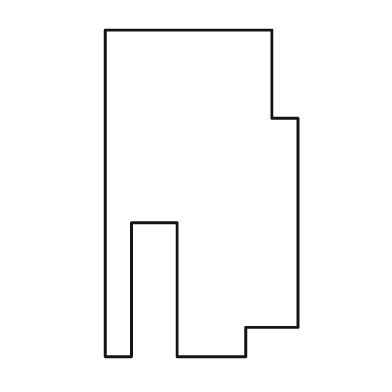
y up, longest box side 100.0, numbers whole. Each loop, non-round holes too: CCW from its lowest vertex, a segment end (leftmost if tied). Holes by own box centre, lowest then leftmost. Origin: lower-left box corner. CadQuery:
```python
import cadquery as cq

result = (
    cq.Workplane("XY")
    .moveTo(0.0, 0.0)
    .lineTo(8.0, 0.0)
    .lineTo(8.0, 41.0)
    .lineTo(22.0, 41.0)
    .lineTo(22.0, 0.0)
    .lineTo(43.0, 0.0)
    .lineTo(43.0, 9.0)
    .lineTo(59.0, 9.0)
    .lineTo(59.0, 73.0)
    .lineTo(51.0, 73.0)
    .lineTo(51.0, 100.0)
    .lineTo(0.0, 100.0)
    .close()
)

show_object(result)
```